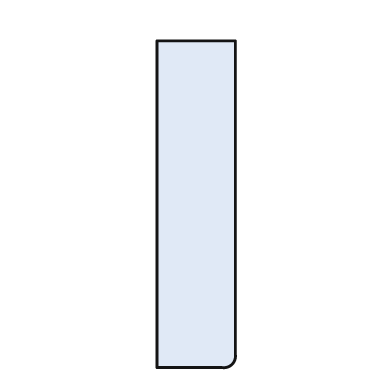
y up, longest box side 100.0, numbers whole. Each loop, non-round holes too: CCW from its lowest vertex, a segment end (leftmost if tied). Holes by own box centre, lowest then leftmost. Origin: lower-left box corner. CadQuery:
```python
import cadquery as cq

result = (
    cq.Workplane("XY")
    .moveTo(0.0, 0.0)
    .lineTo(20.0, 0.0)
    .threePointArc((23.0, 1.0), (24.0, 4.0))
    .lineTo(24.0, 100.0)
    .lineTo(0.0, 100.0)
    .close()
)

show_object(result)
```